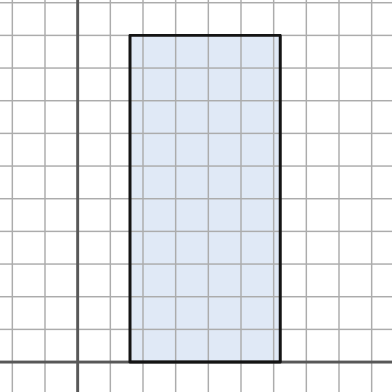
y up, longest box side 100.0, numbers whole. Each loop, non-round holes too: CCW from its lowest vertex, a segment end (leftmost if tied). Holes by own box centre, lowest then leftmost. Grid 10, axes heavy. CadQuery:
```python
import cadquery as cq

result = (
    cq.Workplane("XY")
    .moveTo(16.0, 0.0)
    .lineTo(62.0, 0.0)
    .lineTo(62.0, 100.0)
    .lineTo(16.0, 100.0)
    .close()
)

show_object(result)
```